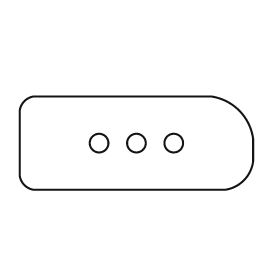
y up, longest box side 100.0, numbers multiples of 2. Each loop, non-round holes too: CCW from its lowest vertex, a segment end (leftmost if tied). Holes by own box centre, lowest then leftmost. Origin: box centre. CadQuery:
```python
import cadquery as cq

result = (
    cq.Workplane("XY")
    .moveTo(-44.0, -20.0)
    .lineTo(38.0, -20.0)
    .threePointArc((46.0, -16.0), (50.0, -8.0))
    .lineTo(50.0, 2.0)
    .threePointArc((44.0, 14.0), (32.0, 20.0))
    .lineTo(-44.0, 20.0)
    .threePointArc((-48.0, 18.0), (-50.0, 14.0))
    .lineTo(-50.0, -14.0)
    .threePointArc((-48.0, -18.0), (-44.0, -20.0))
    .close()
    .moveTo(-16.0, 0.0)
    .circle(4.0)
    .moveTo(0.0, 0.0)
    .circle(4.0)
    .moveTo(16.0, 0.0)
    .circle(4.0)
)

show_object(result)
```